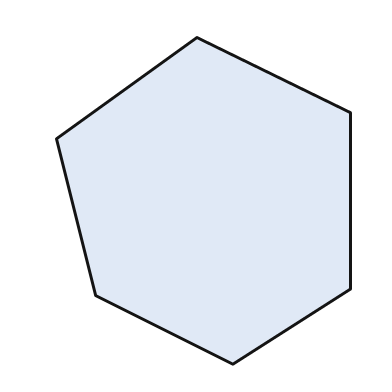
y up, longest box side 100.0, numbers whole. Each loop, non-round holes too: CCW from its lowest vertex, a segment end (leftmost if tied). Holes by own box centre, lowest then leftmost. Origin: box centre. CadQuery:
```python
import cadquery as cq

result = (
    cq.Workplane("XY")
    .moveTo(9.0, -50.0)
    .lineTo(45.0, -27.0)
    .lineTo(45.0, 27.0)
    .lineTo(-2.0, 50.0)
    .lineTo(-45.0, 19.0)
    .lineTo(-33.0, -29.0)
    .close()
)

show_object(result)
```